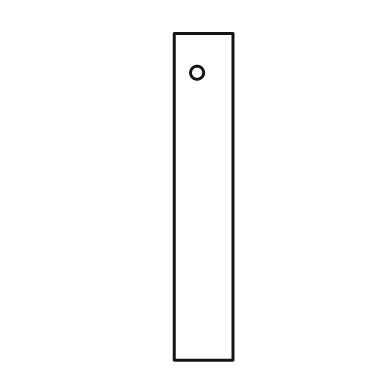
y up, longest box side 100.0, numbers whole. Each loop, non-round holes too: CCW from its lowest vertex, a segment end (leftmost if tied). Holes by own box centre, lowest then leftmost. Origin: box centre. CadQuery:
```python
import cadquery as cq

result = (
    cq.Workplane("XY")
    .moveTo(-9.0, -50.0)
    .lineTo(9.0, -50.0)
    .lineTo(9.0, 50.0)
    .lineTo(-9.0, 50.0)
    .close()
    .moveTo(-2.0, 38.0)
    .circle(2.0)
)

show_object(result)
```